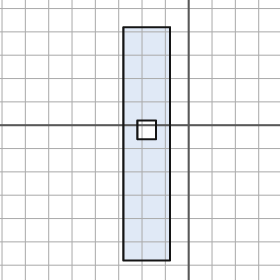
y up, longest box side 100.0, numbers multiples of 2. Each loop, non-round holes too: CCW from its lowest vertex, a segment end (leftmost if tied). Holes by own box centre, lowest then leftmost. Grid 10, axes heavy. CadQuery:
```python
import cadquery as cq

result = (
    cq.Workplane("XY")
    .moveTo(-28.0, -58.0)
    .lineTo(-8.0, -58.0)
    .lineTo(-8.0, 42.0)
    .lineTo(-28.0, 42.0)
    .close()
    .moveTo(-22.0, -6.0)
    .lineTo(-14.0, -6.0)
    .lineTo(-14.0, 2.0)
    .lineTo(-22.0, 2.0)
    .close()
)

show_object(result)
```